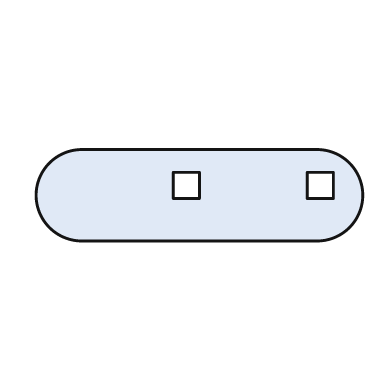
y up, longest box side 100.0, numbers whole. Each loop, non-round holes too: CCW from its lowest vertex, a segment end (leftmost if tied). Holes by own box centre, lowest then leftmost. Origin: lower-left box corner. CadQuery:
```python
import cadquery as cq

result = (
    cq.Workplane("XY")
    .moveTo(14.0, 0.0)
    .lineTo(86.0, 0.0)
    .threePointArc((100.0, 14.0), (86.0, 28.0))
    .lineTo(14.0, 28.0)
    .threePointArc((0.0, 14.0), (14.0, 0.0))
    .close()
    .moveTo(42.0, 13.0)
    .lineTo(50.0, 13.0)
    .lineTo(50.0, 21.0)
    .lineTo(42.0, 21.0)
    .close()
    .moveTo(83.0, 13.0)
    .lineTo(91.0, 13.0)
    .lineTo(91.0, 21.0)
    .lineTo(83.0, 21.0)
    .close()
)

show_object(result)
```